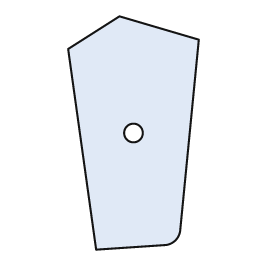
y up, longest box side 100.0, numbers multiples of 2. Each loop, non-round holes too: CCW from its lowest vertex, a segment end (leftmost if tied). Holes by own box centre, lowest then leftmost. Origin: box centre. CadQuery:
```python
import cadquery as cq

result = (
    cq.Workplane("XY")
    .moveTo(-16.0, -50.0)
    .lineTo(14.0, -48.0)
    .threePointArc((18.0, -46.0), (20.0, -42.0))
    .lineTo(28.0, 40.0)
    .lineTo(-6.0, 50.0)
    .lineTo(-28.0, 36.0)
    .close()
    .moveTo(0.0, 0.0)
    .circle(4.0)
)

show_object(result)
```